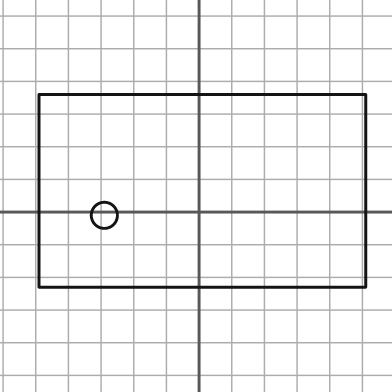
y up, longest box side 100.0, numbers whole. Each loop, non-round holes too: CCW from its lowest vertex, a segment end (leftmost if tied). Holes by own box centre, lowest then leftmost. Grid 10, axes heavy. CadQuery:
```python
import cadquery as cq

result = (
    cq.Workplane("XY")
    .moveTo(-49.0, -23.0)
    .lineTo(51.0, -23.0)
    .lineTo(51.0, 36.0)
    .lineTo(-49.0, 36.0)
    .close()
    .moveTo(-29.0, -1.0)
    .circle(4.0)
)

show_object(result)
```